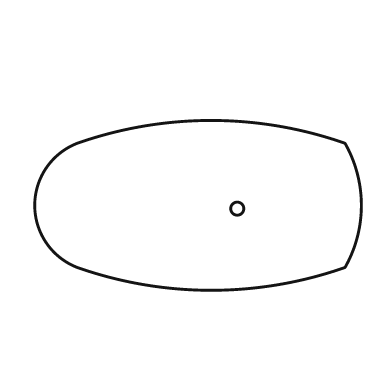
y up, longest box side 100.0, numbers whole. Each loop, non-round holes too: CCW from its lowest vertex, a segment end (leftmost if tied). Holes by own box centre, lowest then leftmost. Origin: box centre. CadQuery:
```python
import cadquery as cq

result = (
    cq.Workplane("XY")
    .moveTo(-37.0, -19.0)
    .threePointArc((4.0, -26.0), (45.0, -19.0))
    .threePointArc((50.0, 0.0), (45.0, 19.0))
    .threePointArc((4.0, 26.0), (-37.0, 19.0))
    .threePointArc((-50.0, 0.0), (-37.0, -19.0))
    .close()
    .moveTo(12.0, -1.0)
    .circle(2.0)
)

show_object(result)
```